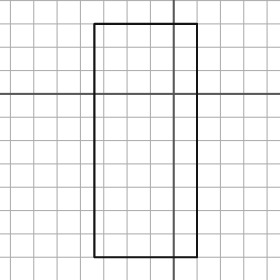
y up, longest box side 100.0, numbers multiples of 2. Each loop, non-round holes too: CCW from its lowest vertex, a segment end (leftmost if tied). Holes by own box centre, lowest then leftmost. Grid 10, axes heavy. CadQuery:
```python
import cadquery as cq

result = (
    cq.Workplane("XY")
    .moveTo(-34.0, -70.0)
    .lineTo(10.0, -70.0)
    .lineTo(10.0, 30.0)
    .lineTo(-34.0, 30.0)
    .close()
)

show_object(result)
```